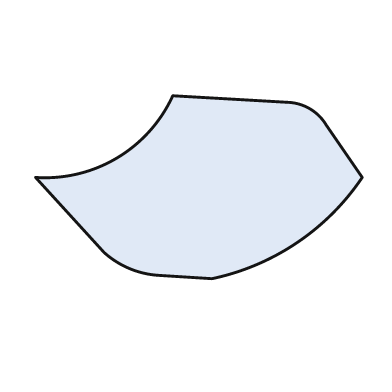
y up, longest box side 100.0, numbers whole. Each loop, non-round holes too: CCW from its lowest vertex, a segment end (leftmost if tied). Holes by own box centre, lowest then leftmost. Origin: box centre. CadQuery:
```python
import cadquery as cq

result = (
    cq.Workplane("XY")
    .moveTo(4.0, -28.0)
    .threePointArc((30.0, -17.0), (50.0, 3.0))
    .lineTo(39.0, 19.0)
    .threePointArc((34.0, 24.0), (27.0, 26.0))
    .lineTo(-8.0, 28.0)
    .threePointArc((-25.0, 9.0), (-50.0, 3.0))
    .lineTo(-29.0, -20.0)
    .threePointArc((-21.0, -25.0), (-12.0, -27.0))
    .close()
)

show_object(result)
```